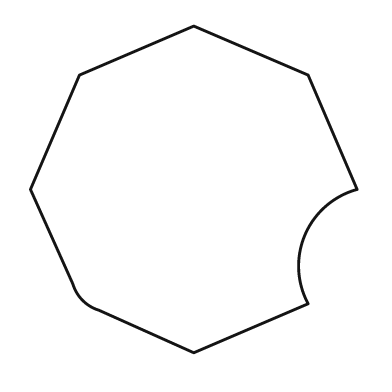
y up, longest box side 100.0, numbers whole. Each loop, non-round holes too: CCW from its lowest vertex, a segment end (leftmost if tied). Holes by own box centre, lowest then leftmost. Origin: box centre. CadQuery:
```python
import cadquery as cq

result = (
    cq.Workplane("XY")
    .moveTo(0.0, -50.0)
    .lineTo(35.0, -35.0)
    .threePointArc((34.0, -14.0), (50.0, 0.0))
    .lineTo(35.0, 35.0)
    .lineTo(0.0, 50.0)
    .lineTo(-35.0, 35.0)
    .lineTo(-50.0, 0.0)
    .lineTo(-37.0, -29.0)
    .threePointArc((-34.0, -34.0), (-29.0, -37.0))
    .close()
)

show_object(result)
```